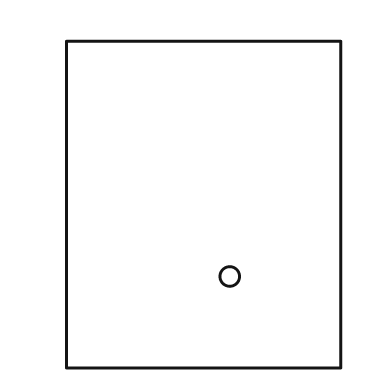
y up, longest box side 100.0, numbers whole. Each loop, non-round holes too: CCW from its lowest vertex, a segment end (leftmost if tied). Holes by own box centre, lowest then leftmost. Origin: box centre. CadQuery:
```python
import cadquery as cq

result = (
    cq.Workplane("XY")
    .moveTo(-42.0, -50.0)
    .lineTo(42.0, -50.0)
    .lineTo(42.0, 50.0)
    .lineTo(-42.0, 50.0)
    .close()
    .moveTo(8.0, -22.0)
    .circle(3.0)
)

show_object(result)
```